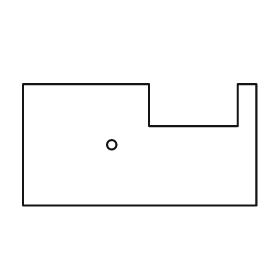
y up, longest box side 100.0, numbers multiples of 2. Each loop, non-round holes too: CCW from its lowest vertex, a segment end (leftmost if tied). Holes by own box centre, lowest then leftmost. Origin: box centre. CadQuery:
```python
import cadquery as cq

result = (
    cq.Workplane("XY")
    .moveTo(-50.0, -26.0)
    .lineTo(50.0, -26.0)
    .lineTo(50.0, 26.0)
    .lineTo(42.0, 26.0)
    .lineTo(42.0, 8.0)
    .lineTo(4.0, 8.0)
    .lineTo(4.0, 26.0)
    .lineTo(-50.0, 26.0)
    .close()
    .moveTo(-12.0, 0.0)
    .circle(2.0)
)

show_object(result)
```